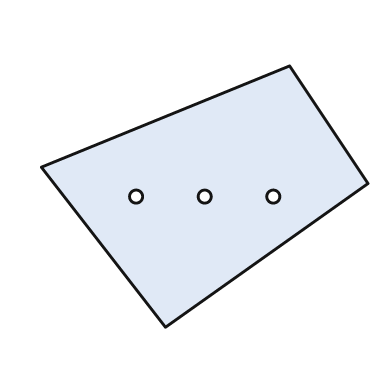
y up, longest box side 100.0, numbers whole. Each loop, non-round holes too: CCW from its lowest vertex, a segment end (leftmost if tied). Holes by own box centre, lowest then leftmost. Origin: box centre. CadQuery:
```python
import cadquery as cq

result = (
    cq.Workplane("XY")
    .moveTo(-12.0, -40.0)
    .lineTo(50.0, 4.0)
    .lineTo(26.0, 40.0)
    .lineTo(-50.0, 9.0)
    .close()
    .moveTo(-21.0, 0.0)
    .circle(2.0)
    .moveTo(0.0, 0.0)
    .circle(2.0)
    .moveTo(21.0, 0.0)
    .circle(2.0)
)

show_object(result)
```